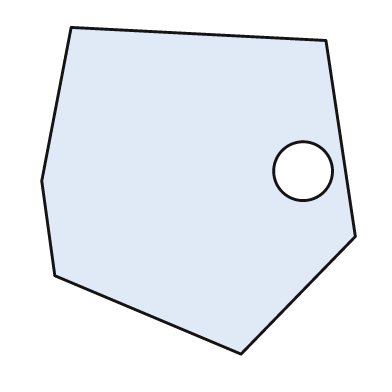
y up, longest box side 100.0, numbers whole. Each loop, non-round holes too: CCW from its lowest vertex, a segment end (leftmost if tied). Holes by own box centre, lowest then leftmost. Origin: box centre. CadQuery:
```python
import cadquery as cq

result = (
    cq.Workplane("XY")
    .moveTo(13.0, -50.0)
    .lineTo(48.0, -14.0)
    .lineTo(39.0, 46.0)
    .lineTo(-39.0, 50.0)
    .lineTo(-48.0, 3.0)
    .lineTo(-44.0, -26.0)
    .close()
    .moveTo(32.0, 6.0)
    .circle(9.0)
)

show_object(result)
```